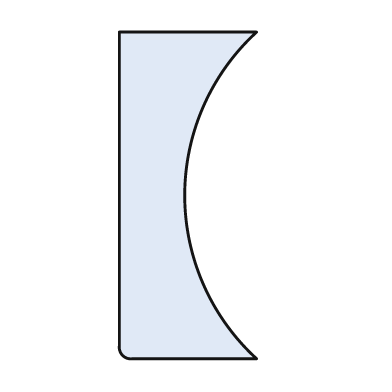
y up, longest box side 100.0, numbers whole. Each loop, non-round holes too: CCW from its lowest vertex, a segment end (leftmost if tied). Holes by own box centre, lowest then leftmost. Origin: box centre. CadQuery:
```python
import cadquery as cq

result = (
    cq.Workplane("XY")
    .moveTo(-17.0, -50.0)
    .lineTo(21.0, -50.0)
    .threePointArc((-1.0, 0.0), (21.0, 50.0))
    .lineTo(-21.0, 50.0)
    .lineTo(-21.0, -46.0)
    .threePointArc((-20.0, -49.0), (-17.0, -50.0))
    .close()
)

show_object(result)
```